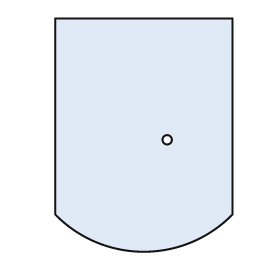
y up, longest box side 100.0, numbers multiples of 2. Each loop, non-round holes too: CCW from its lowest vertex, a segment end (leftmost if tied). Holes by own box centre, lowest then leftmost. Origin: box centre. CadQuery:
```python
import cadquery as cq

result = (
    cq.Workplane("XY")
    .moveTo(-38.0, -34.0)
    .threePointArc((0.0, -50.0), (38.0, -34.0))
    .lineTo(38.0, 50.0)
    .lineTo(-38.0, 50.0)
    .close()
    .moveTo(10.0, -2.0)
    .circle(2.0)
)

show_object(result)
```